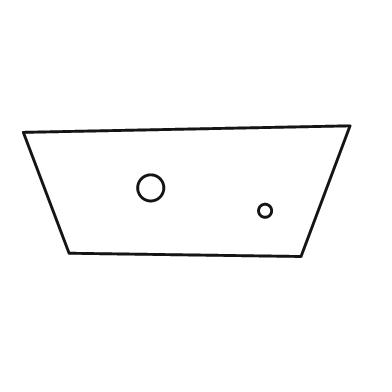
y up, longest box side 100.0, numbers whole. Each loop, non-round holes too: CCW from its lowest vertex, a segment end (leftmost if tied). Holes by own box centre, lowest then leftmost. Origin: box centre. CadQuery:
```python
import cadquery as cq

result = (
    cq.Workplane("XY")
    .moveTo(35.0, -20.0)
    .lineTo(50.0, 20.0)
    .lineTo(-50.0, 18.0)
    .lineTo(-36.0, -19.0)
    .close()
    .moveTo(24.0, -6.0)
    .circle(2.0)
    .moveTo(-11.0, 1.0)
    .circle(4.0)
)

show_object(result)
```